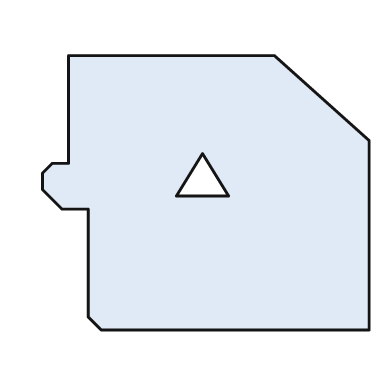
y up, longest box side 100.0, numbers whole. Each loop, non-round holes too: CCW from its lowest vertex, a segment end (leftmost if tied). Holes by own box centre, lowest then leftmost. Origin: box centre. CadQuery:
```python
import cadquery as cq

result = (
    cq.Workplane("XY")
    .moveTo(-32.0, -42.0)
    .lineTo(50.0, -42.0)
    .lineTo(50.0, 16.0)
    .lineTo(21.0, 42.0)
    .lineTo(-42.0, 42.0)
    .lineTo(-42.0, 9.0)
    .lineTo(-47.0, 9.0)
    .lineTo(-50.0, 6.0)
    .lineTo(-50.0, 1.0)
    .lineTo(-44.0, -5.0)
    .lineTo(-36.0, -5.0)
    .lineTo(-36.0, -38.0)
    .close()
    .moveTo(-9.0, -1.0)
    .lineTo(7.0, -1.0)
    .lineTo(-1.0, 12.0)
    .close()
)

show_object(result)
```